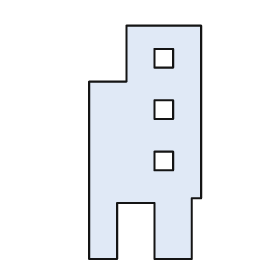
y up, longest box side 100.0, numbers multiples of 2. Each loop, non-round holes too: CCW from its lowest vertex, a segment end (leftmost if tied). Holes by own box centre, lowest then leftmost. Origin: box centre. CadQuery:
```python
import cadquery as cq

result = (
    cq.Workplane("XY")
    .moveTo(-24.0, -50.0)
    .lineTo(-12.0, -50.0)
    .lineTo(-12.0, -26.0)
    .lineTo(4.0, -26.0)
    .lineTo(4.0, -50.0)
    .lineTo(20.0, -50.0)
    .lineTo(20.0, -24.0)
    .lineTo(24.0, -24.0)
    .lineTo(24.0, 50.0)
    .lineTo(-8.0, 50.0)
    .lineTo(-8.0, 26.0)
    .lineTo(-24.0, 26.0)
    .close()
    .moveTo(4.0, -12.0)
    .lineTo(12.0, -12.0)
    .lineTo(12.0, -4.0)
    .lineTo(4.0, -4.0)
    .close()
    .moveTo(4.0, 10.0)
    .lineTo(12.0, 10.0)
    .lineTo(12.0, 18.0)
    .lineTo(4.0, 18.0)
    .close()
    .moveTo(4.0, 32.0)
    .lineTo(12.0, 32.0)
    .lineTo(12.0, 40.0)
    .lineTo(4.0, 40.0)
    .close()
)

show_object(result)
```